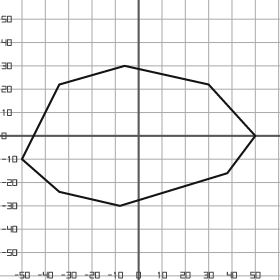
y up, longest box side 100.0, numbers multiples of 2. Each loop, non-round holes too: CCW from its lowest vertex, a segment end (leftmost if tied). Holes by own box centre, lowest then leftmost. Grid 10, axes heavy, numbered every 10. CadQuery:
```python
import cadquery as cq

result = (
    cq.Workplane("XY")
    .moveTo(-8.0, -30.0)
    .lineTo(38.0, -16.0)
    .lineTo(50.0, 0.0)
    .lineTo(30.0, 22.0)
    .lineTo(-6.0, 30.0)
    .lineTo(-34.0, 22.0)
    .lineTo(-50.0, -10.0)
    .lineTo(-34.0, -24.0)
    .close()
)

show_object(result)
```